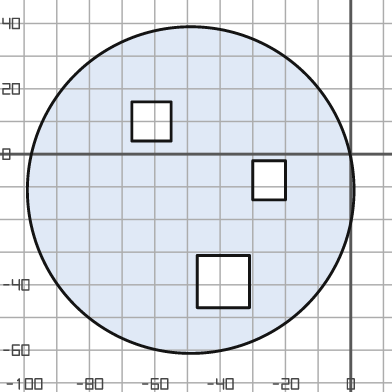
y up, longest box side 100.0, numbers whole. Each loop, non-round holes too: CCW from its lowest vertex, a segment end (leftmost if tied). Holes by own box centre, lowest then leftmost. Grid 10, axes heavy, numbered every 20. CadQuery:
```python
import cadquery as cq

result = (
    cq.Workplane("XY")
    .moveTo(-49.0, -11.0)
    .circle(50.0)
    .moveTo(-47.0, -47.0)
    .lineTo(-31.0, -47.0)
    .lineTo(-31.0, -31.0)
    .lineTo(-47.0, -31.0)
    .close()
    .moveTo(-30.0, -14.0)
    .lineTo(-20.0, -14.0)
    .lineTo(-20.0, -2.0)
    .lineTo(-30.0, -2.0)
    .close()
    .moveTo(-67.0, 4.0)
    .lineTo(-55.0, 4.0)
    .lineTo(-55.0, 16.0)
    .lineTo(-67.0, 16.0)
    .close()
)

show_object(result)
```